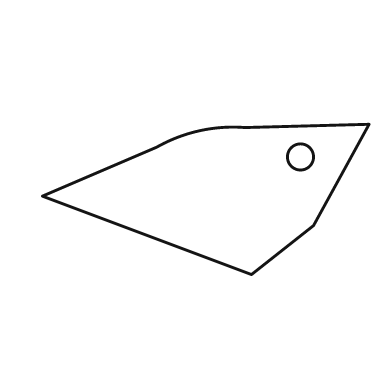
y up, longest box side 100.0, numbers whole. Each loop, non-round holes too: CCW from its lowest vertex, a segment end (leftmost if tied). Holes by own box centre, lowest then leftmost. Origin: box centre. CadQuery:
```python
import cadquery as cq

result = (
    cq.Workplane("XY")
    .moveTo(14.0, -23.0)
    .lineTo(33.0, -8.0)
    .lineTo(50.0, 23.0)
    .lineTo(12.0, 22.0)
    .threePointArc((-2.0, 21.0), (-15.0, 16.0))
    .lineTo(-50.0, 1.0)
    .close()
    .moveTo(29.0, 13.0)
    .circle(4.0)
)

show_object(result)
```